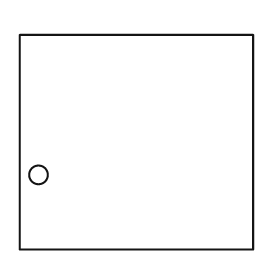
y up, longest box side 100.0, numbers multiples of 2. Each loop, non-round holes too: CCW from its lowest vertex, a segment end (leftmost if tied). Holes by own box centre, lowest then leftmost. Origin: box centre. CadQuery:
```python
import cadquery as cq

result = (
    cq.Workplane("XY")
    .moveTo(-50.0, -46.0)
    .lineTo(50.0, -46.0)
    .lineTo(50.0, 46.0)
    .lineTo(-50.0, 46.0)
    .close()
    .moveTo(-42.0, -14.0)
    .circle(4.0)
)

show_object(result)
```